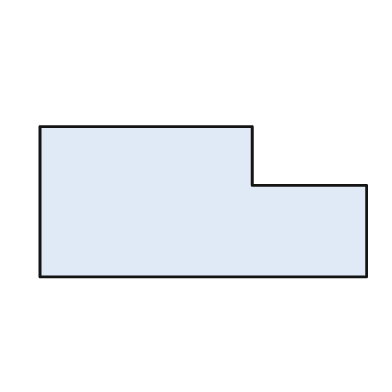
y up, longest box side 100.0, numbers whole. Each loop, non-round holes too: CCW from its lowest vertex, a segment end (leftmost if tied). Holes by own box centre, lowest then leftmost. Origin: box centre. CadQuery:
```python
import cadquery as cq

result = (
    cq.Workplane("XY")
    .moveTo(-50.0, -23.0)
    .lineTo(50.0, -23.0)
    .lineTo(50.0, 5.0)
    .lineTo(15.0, 5.0)
    .lineTo(15.0, 23.0)
    .lineTo(-50.0, 23.0)
    .close()
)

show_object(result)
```